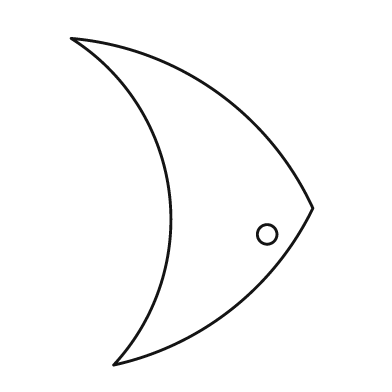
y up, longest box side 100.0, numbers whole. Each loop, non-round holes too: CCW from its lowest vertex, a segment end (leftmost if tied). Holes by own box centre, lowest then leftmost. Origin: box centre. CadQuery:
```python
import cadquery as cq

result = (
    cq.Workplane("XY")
    .moveTo(-24.0, -50.0)
    .threePointArc((12.0, -33.0), (37.0, -2.0))
    .threePointArc((7.0, 34.0), (-37.0, 50.0))
    .threePointArc((-7.0, 3.0), (-24.0, -50.0))
    .close()
    .moveTo(23.0, -10.0)
    .circle(3.0)
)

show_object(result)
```